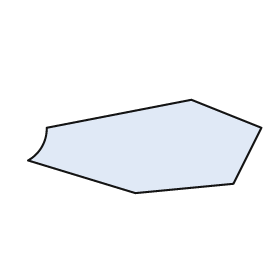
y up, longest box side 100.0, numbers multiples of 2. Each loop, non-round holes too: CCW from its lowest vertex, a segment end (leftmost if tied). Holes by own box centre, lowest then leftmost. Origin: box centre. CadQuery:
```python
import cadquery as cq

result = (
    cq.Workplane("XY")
    .moveTo(-4.0, -20.0)
    .lineTo(38.0, -16.0)
    .lineTo(50.0, 8.0)
    .lineTo(20.0, 20.0)
    .lineTo(-42.0, 8.0)
    .threePointArc((-44.0, 0.0), (-50.0, -6.0))
    .close()
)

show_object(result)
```